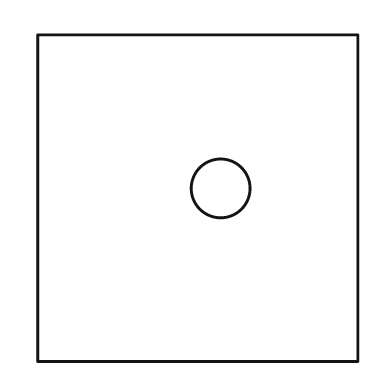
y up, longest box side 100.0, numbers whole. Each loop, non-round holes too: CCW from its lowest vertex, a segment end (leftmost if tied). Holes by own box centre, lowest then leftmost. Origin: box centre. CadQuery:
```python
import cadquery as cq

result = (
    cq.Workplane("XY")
    .moveTo(-49.0, -50.0)
    .lineTo(49.0, -50.0)
    .lineTo(49.0, 50.0)
    .lineTo(-49.0, 50.0)
    .close()
    .moveTo(7.0, 3.0)
    .circle(9.0)
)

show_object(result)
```